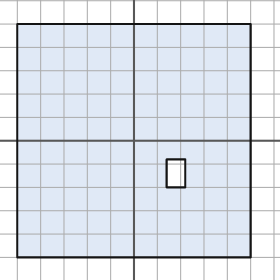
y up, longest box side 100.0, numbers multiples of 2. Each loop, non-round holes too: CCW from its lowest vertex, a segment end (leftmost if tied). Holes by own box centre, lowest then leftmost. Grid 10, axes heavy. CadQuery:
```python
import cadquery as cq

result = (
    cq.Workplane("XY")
    .moveTo(-50.0, -50.0)
    .lineTo(50.0, -50.0)
    .lineTo(50.0, 50.0)
    .lineTo(-50.0, 50.0)
    .close()
    .moveTo(14.0, -20.0)
    .lineTo(22.0, -20.0)
    .lineTo(22.0, -8.0)
    .lineTo(14.0, -8.0)
    .close()
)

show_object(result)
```